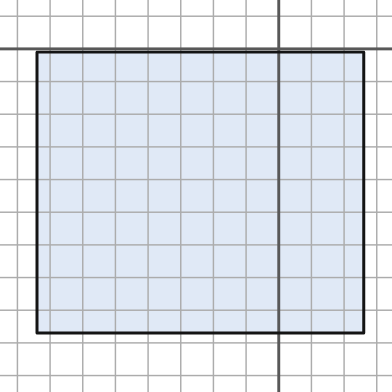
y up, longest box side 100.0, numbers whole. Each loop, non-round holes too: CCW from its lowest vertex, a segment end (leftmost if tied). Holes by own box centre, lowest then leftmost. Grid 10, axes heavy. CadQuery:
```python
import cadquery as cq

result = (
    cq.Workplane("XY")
    .moveTo(-74.0, -87.0)
    .lineTo(26.0, -87.0)
    .lineTo(26.0, -1.0)
    .lineTo(-74.0, -1.0)
    .close()
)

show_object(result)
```